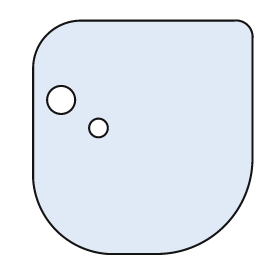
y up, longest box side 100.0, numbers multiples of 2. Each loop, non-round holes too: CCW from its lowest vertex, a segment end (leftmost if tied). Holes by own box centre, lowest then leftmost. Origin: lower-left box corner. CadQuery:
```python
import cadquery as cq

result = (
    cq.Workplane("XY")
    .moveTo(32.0, 0.0)
    .lineTo(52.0, 0.0)
    .threePointArc((82.0, 12.0), (94.0, 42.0))
    .lineTo(94.0, 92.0)
    .threePointArc((92.0, 98.0), (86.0, 100.0))
    .lineTo(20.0, 100.0)
    .threePointArc((6.0, 94.0), (0.0, 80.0))
    .lineTo(0.0, 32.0)
    .threePointArc((10.0, 10.0), (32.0, 0.0))
    .close()
    .moveTo(28.0, 54.0)
    .circle(4.0)
    .moveTo(12.0, 66.0)
    .circle(6.0)
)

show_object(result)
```